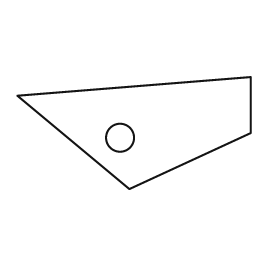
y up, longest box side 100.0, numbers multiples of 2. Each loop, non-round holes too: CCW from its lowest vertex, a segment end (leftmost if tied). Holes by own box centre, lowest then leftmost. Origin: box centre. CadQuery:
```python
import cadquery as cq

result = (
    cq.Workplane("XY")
    .moveTo(-2.0, -24.0)
    .lineTo(50.0, 0.0)
    .lineTo(50.0, 24.0)
    .lineTo(-50.0, 16.0)
    .close()
    .moveTo(-6.0, -2.0)
    .circle(6.0)
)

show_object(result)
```